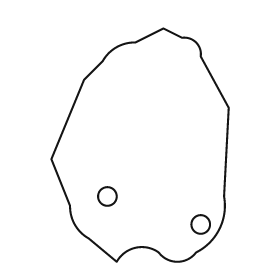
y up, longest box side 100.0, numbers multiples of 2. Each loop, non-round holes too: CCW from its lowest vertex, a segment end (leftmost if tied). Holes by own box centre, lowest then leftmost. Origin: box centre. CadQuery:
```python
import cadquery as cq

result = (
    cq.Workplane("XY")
    .moveTo(-10.0, -50.0)
    .threePointArc((-2.0, -44.0), (8.0, -46.0))
    .threePointArc((16.0, -50.0), (24.0, -46.0))
    .threePointArc((34.0, -36.0), (36.0, -22.0))
    .lineTo(38.0, 16.0)
    .lineTo(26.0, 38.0)
    .threePointArc((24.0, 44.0), (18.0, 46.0))
    .lineTo(10.0, 50.0)
    .lineTo(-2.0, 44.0)
    .threePointArc((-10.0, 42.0), (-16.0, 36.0))
    .lineTo(-24.0, 28.0)
    .lineTo(-38.0, -6.0)
    .lineTo(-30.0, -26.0)
    .threePointArc((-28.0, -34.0), (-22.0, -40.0))
    .close()
    .moveTo(26.0, -34.0)
    .circle(4.0)
    .moveTo(-14.0, -22.0)
    .circle(4.0)
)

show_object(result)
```